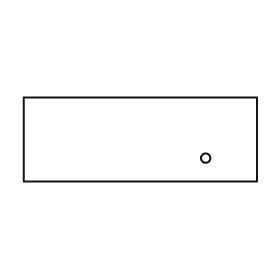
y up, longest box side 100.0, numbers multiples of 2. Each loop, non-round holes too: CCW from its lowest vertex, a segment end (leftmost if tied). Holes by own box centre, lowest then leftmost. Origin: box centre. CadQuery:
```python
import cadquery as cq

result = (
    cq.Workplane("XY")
    .moveTo(-50.0, -18.0)
    .lineTo(50.0, -18.0)
    .lineTo(50.0, 18.0)
    .lineTo(-50.0, 18.0)
    .close()
    .moveTo(28.0, -8.0)
    .circle(2.0)
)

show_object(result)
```